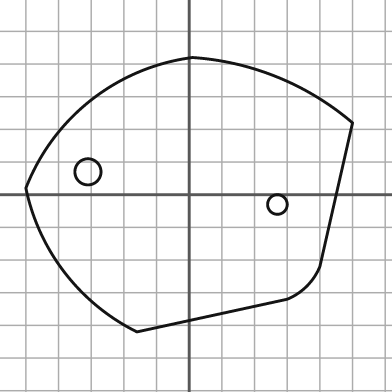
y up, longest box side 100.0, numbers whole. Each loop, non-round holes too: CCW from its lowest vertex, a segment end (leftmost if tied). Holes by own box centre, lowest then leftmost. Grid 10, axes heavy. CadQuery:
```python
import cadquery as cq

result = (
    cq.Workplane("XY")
    .moveTo(-16.0, -42.0)
    .lineTo(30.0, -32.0)
    .threePointArc((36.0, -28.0), (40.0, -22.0))
    .lineTo(50.0, 22.0)
    .threePointArc((27.0, 36.0), (1.0, 42.0))
    .threePointArc((-30.0, 29.0), (-50.0, 2.0))
    .threePointArc((-38.0, -24.0), (-16.0, -42.0))
    .close()
    .moveTo(27.0, -3.0)
    .circle(3.0)
    .moveTo(-31.0, 7.0)
    .circle(4.0)
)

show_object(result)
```